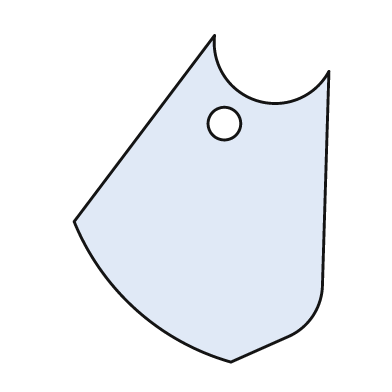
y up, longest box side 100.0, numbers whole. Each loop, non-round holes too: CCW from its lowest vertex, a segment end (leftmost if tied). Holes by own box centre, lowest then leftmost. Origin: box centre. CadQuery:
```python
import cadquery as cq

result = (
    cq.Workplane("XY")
    .moveTo(9.0, -50.0)
    .lineTo(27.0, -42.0)
    .threePointArc((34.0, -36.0), (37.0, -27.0))
    .lineTo(39.0, 39.0)
    .threePointArc((17.0, 30.0), (4.0, 50.0))
    .lineTo(-39.0, -7.0)
    .threePointArc((-20.0, -34.0), (9.0, -50.0))
    .close()
    .moveTo(7.0, 23.0)
    .circle(5.0)
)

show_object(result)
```